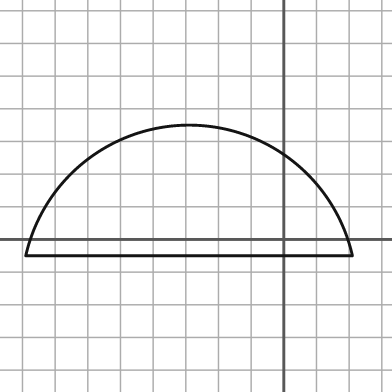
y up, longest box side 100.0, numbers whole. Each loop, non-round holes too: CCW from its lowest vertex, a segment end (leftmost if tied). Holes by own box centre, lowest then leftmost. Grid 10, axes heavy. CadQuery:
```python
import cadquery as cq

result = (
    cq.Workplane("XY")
    .moveTo(-79.0, -5.0)
    .lineTo(21.0, -5.0)
    .threePointArc((-29.0, 35.0), (-79.0, -5.0))
    .close()
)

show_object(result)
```